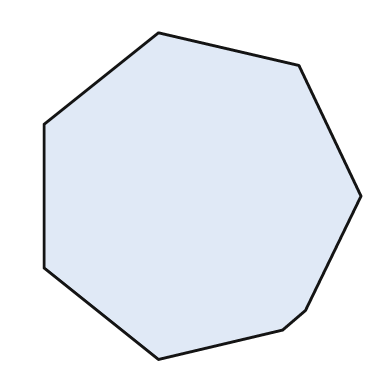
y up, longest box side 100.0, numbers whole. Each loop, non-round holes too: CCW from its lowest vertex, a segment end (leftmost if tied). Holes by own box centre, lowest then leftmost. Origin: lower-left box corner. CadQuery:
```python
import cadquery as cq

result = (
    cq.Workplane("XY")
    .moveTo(35.0, 0.0)
    .lineTo(73.0, 9.0)
    .lineTo(80.0, 15.0)
    .lineTo(97.0, 50.0)
    .lineTo(78.0, 90.0)
    .lineTo(35.0, 100.0)
    .lineTo(0.0, 72.0)
    .lineTo(0.0, 28.0)
    .close()
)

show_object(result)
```